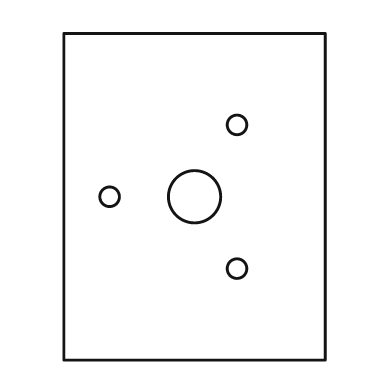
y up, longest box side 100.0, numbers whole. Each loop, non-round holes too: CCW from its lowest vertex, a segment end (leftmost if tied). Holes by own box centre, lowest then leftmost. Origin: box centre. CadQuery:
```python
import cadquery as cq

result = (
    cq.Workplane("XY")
    .moveTo(-40.0, -50.0)
    .lineTo(40.0, -50.0)
    .lineTo(40.0, 50.0)
    .lineTo(-40.0, 50.0)
    .close()
    .moveTo(13.0, -22.0)
    .circle(3.0)
    .moveTo(-26.0, 0.0)
    .circle(3.0)
    .moveTo(0.0, 0.0)
    .circle(8.0)
    .moveTo(13.0, 22.0)
    .circle(3.0)
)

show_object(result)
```